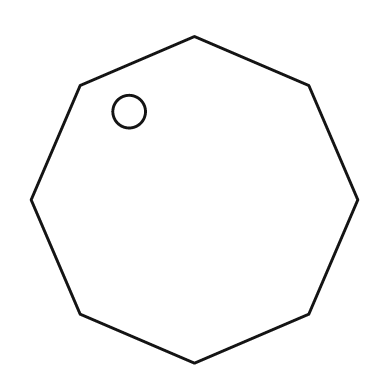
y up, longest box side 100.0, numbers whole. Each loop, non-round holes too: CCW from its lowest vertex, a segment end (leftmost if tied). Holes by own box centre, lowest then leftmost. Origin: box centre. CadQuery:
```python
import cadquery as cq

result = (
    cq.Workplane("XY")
    .moveTo(0.0, -50.0)
    .lineTo(35.0, -35.0)
    .lineTo(50.0, 0.0)
    .lineTo(35.0, 35.0)
    .lineTo(0.0, 50.0)
    .lineTo(-35.0, 35.0)
    .lineTo(-50.0, 0.0)
    .lineTo(-35.0, -35.0)
    .close()
    .moveTo(-20.0, 27.0)
    .circle(5.0)
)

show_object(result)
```